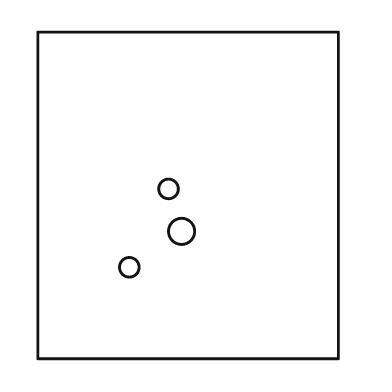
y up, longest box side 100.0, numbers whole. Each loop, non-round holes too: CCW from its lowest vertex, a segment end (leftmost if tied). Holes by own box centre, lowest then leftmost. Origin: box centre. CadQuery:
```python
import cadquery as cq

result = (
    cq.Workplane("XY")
    .moveTo(-46.0, -50.0)
    .lineTo(46.0, -50.0)
    .lineTo(46.0, 50.0)
    .lineTo(-46.0, 50.0)
    .close()
    .moveTo(-18.0, -22.0)
    .circle(3.0)
    .moveTo(-2.0, -11.0)
    .circle(4.0)
    .moveTo(-6.0, 2.0)
    .circle(3.0)
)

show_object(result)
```